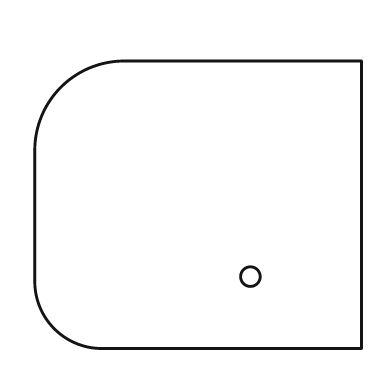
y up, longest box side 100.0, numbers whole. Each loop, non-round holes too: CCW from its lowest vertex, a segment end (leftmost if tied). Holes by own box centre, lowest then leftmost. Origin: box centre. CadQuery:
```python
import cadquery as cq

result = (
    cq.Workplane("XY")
    .moveTo(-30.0, -44.0)
    .lineTo(50.0, -44.0)
    .lineTo(50.0, 44.0)
    .lineTo(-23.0, 44.0)
    .threePointArc((-42.0, 36.0), (-50.0, 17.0))
    .lineTo(-50.0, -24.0)
    .threePointArc((-44.0, -38.0), (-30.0, -44.0))
    .close()
    .moveTo(16.0, -22.0)
    .circle(3.0)
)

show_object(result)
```